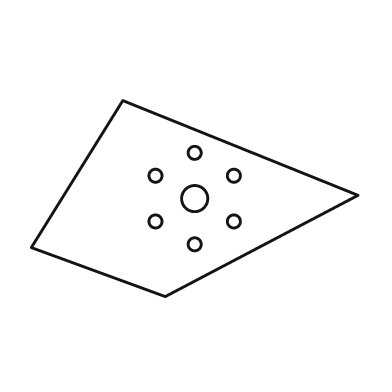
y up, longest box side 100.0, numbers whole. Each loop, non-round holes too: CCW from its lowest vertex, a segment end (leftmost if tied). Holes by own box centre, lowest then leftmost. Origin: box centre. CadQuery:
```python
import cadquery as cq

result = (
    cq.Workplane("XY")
    .moveTo(-9.0, -30.0)
    .lineTo(50.0, 1.0)
    .lineTo(-22.0, 30.0)
    .lineTo(-50.0, -15.0)
    .close()
    .moveTo(0.0, -14.0)
    .circle(2.0)
    .moveTo(-12.0, -7.0)
    .circle(2.0)
    .moveTo(12.0, -7.0)
    .circle(2.0)
    .moveTo(0.0, 0.0)
    .circle(4.0)
    .moveTo(-12.0, 7.0)
    .circle(2.0)
    .moveTo(12.0, 7.0)
    .circle(2.0)
    .moveTo(0.0, 14.0)
    .circle(2.0)
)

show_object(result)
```